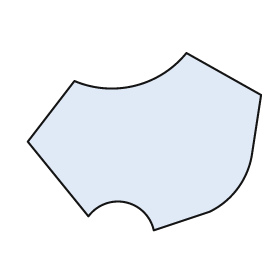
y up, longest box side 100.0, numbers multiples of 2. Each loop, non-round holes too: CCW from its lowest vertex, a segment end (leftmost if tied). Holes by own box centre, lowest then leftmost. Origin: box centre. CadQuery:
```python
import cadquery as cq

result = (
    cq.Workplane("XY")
    .moveTo(4.0, -38.0)
    .lineTo(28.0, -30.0)
    .threePointArc((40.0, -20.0), (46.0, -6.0))
    .lineTo(50.0, 20.0)
    .lineTo(18.0, 38.0)
    .threePointArc((-4.0, 24.0), (-30.0, 26.0))
    .lineTo(-50.0, 0.0)
    .lineTo(-24.0, -32.0)
    .threePointArc((-8.0, -26.0), (4.0, -38.0))
    .close()
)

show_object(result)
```